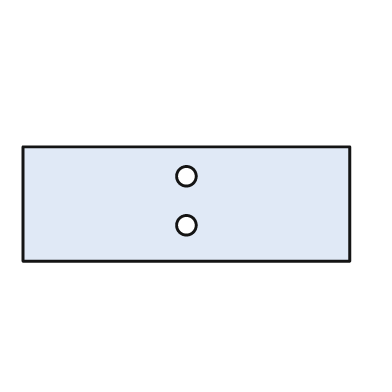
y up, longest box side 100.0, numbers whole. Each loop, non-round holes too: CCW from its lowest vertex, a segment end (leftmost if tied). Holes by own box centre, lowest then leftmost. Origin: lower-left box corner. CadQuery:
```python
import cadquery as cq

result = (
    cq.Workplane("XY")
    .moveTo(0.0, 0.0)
    .lineTo(100.0, 0.0)
    .lineTo(100.0, 35.0)
    .lineTo(0.0, 35.0)
    .close()
    .moveTo(50.0, 11.0)
    .circle(3.0)
    .moveTo(50.0, 26.0)
    .circle(3.0)
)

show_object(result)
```